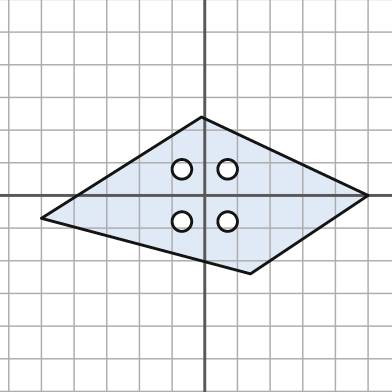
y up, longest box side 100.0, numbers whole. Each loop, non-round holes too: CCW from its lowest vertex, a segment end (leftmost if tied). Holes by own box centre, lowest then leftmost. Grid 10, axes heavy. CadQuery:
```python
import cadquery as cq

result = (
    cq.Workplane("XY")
    .moveTo(14.0, -24.0)
    .lineTo(50.0, 0.0)
    .lineTo(-1.0, 24.0)
    .lineTo(-50.0, -7.0)
    .close()
    .moveTo(-7.0, -8.0)
    .circle(3.0)
    .moveTo(7.0, -8.0)
    .circle(3.0)
    .moveTo(-7.0, 8.0)
    .circle(3.0)
    .moveTo(7.0, 8.0)
    .circle(3.0)
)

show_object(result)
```